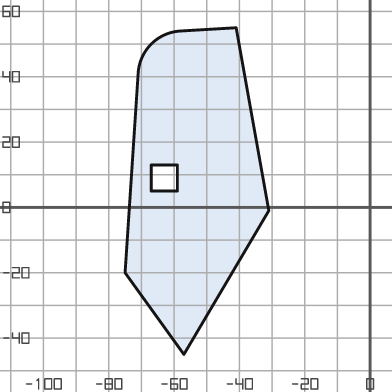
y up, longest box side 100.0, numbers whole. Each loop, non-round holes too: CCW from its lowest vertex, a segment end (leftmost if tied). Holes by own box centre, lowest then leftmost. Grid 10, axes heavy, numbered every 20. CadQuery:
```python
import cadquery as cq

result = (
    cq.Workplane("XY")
    .moveTo(-57.0, -45.0)
    .lineTo(-31.0, -1.0)
    .lineTo(-41.0, 55.0)
    .lineTo(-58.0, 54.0)
    .threePointArc((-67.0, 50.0), (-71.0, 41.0))
    .lineTo(-75.0, -20.0)
    .close()
    .moveTo(-67.0, 5.0)
    .lineTo(-59.0, 5.0)
    .lineTo(-59.0, 13.0)
    .lineTo(-67.0, 13.0)
    .close()
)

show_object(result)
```